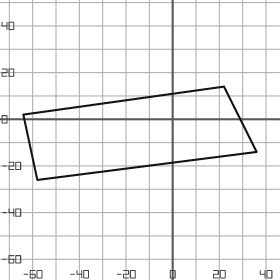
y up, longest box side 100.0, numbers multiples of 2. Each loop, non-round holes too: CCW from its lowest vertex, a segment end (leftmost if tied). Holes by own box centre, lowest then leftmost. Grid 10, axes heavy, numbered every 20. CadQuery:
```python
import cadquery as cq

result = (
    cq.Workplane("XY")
    .moveTo(-58.0, -26.0)
    .lineTo(36.0, -14.0)
    .lineTo(22.0, 14.0)
    .lineTo(-64.0, 2.0)
    .close()
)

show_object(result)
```